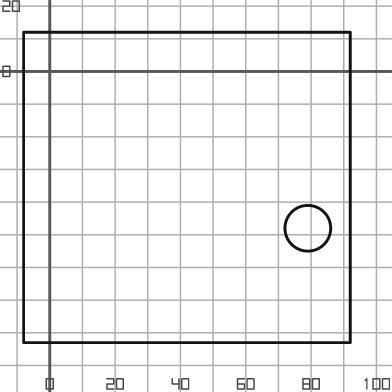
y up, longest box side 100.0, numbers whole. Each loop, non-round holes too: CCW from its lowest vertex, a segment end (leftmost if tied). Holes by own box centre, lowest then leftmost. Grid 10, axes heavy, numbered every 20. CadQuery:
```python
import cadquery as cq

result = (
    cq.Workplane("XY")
    .moveTo(-8.0, -83.0)
    .lineTo(92.0, -83.0)
    .lineTo(92.0, 12.0)
    .lineTo(-8.0, 12.0)
    .close()
    .moveTo(79.0, -48.0)
    .circle(7.0)
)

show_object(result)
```